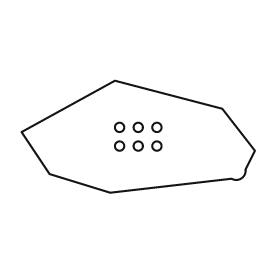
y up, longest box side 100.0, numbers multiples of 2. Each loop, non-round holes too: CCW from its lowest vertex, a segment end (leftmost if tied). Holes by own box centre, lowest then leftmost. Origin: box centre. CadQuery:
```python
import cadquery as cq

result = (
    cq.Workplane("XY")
    .moveTo(-12.0, -24.0)
    .lineTo(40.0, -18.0)
    .threePointArc((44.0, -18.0), (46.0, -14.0))
    .lineTo(50.0, -6.0)
    .lineTo(36.0, 12.0)
    .lineTo(-10.0, 24.0)
    .lineTo(-50.0, 2.0)
    .lineTo(-38.0, -16.0)
    .close()
    .moveTo(-8.0, -4.0)
    .circle(2.0)
    .moveTo(0.0, -4.0)
    .circle(2.0)
    .moveTo(8.0, -4.0)
    .circle(2.0)
    .moveTo(-8.0, 4.0)
    .circle(2.0)
    .moveTo(0.0, 4.0)
    .circle(2.0)
    .moveTo(8.0, 4.0)
    .circle(2.0)
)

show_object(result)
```